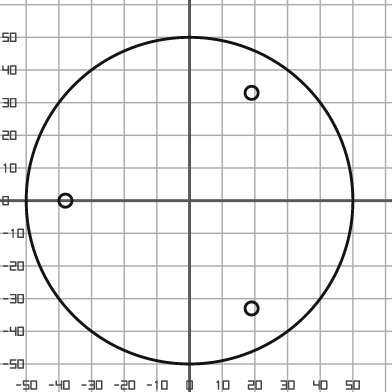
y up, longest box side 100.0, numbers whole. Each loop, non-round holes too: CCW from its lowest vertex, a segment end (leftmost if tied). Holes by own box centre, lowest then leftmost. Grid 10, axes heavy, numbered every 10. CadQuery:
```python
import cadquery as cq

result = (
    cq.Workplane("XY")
    .moveTo(0.0, 0.0)
    .circle(50.0)
    .moveTo(19.0, -33.0)
    .circle(2.0)
    .moveTo(-38.0, 0.0)
    .circle(2.0)
    .moveTo(19.0, 33.0)
    .circle(2.0)
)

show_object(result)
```